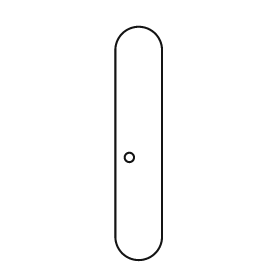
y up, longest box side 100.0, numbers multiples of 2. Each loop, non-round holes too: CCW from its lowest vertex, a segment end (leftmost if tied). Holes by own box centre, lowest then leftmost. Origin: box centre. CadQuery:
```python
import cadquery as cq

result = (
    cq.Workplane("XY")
    .moveTo(-10.0, -40.0)
    .threePointArc((0.0, -50.0), (10.0, -40.0))
    .lineTo(10.0, 40.0)
    .threePointArc((0.0, 50.0), (-10.0, 40.0))
    .close()
    .moveTo(-4.0, -6.0)
    .circle(2.0)
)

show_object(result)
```